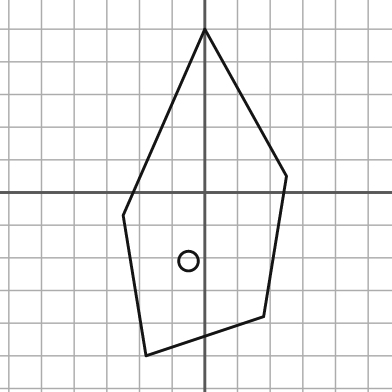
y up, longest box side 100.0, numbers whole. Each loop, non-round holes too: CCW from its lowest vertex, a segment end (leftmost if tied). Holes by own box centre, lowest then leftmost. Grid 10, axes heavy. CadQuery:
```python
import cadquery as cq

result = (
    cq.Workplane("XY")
    .moveTo(-18.0, -50.0)
    .lineTo(18.0, -38.0)
    .lineTo(25.0, 5.0)
    .lineTo(0.0, 50.0)
    .lineTo(-25.0, -7.0)
    .close()
    .moveTo(-5.0, -21.0)
    .circle(3.0)
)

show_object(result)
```